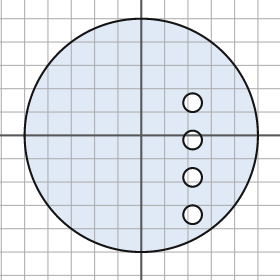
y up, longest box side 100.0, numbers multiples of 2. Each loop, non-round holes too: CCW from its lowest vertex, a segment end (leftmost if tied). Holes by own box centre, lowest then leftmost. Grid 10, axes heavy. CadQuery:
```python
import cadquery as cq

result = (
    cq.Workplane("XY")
    .moveTo(0.0, 0.0)
    .circle(50.0)
    .moveTo(22.0, -34.0)
    .circle(4.0)
    .moveTo(22.0, -18.0)
    .circle(4.0)
    .moveTo(22.0, -2.0)
    .circle(4.0)
    .moveTo(22.0, 14.0)
    .circle(4.0)
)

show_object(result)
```